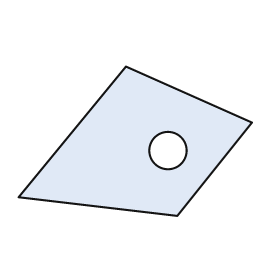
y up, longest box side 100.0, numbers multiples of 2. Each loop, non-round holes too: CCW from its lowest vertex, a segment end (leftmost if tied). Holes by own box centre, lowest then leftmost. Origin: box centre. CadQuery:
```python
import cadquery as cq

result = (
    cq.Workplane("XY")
    .moveTo(18.0, -32.0)
    .lineTo(50.0, 8.0)
    .lineTo(-4.0, 32.0)
    .lineTo(-50.0, -24.0)
    .close()
    .moveTo(14.0, -4.0)
    .circle(8.0)
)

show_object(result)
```